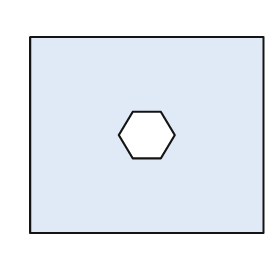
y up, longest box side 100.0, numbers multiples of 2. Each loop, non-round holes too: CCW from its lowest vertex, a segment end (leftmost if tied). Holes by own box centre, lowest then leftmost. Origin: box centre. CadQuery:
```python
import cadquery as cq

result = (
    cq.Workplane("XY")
    .moveTo(-50.0, -42.0)
    .lineTo(50.0, -42.0)
    .lineTo(50.0, 42.0)
    .lineTo(-50.0, 42.0)
    .close()
    .moveTo(-6.0, -10.0)
    .lineTo(6.0, -10.0)
    .lineTo(12.0, 0.0)
    .lineTo(6.0, 10.0)
    .lineTo(-6.0, 10.0)
    .lineTo(-12.0, 0.0)
    .close()
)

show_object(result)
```